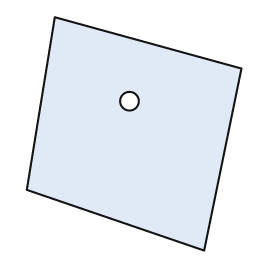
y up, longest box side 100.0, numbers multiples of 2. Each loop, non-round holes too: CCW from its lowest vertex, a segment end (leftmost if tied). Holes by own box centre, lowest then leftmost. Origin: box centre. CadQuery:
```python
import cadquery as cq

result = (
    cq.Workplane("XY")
    .moveTo(30.0, -50.0)
    .lineTo(46.0, 28.0)
    .lineTo(-34.0, 50.0)
    .lineTo(-46.0, -24.0)
    .close()
    .moveTo(-2.0, 14.0)
    .circle(4.0)
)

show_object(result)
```